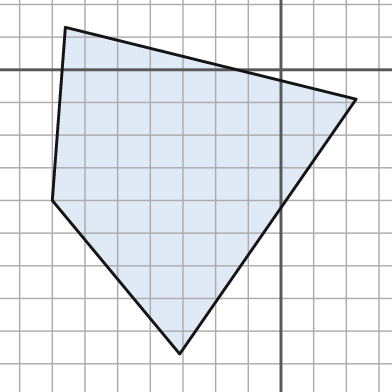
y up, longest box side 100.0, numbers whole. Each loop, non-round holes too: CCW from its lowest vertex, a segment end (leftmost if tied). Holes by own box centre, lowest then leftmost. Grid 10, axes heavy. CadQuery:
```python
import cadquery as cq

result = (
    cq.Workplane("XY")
    .moveTo(-31.0, -87.0)
    .lineTo(23.0, -9.0)
    .lineTo(-66.0, 13.0)
    .lineTo(-70.0, -40.0)
    .close()
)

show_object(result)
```